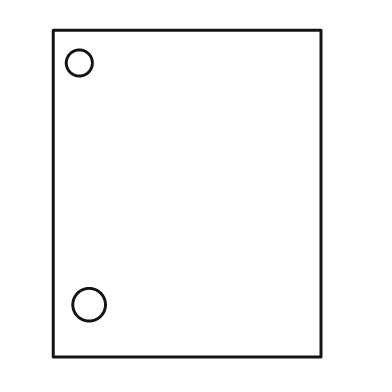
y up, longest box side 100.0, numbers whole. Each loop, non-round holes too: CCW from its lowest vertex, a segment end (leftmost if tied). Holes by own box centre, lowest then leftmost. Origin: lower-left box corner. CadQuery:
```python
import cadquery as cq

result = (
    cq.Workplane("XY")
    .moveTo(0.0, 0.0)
    .lineTo(82.0, 0.0)
    .lineTo(82.0, 100.0)
    .lineTo(0.0, 100.0)
    .close()
    .moveTo(11.0, 16.0)
    .circle(5.0)
    .moveTo(8.0, 90.0)
    .circle(4.0)
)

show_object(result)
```